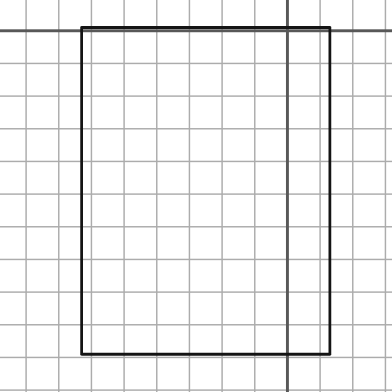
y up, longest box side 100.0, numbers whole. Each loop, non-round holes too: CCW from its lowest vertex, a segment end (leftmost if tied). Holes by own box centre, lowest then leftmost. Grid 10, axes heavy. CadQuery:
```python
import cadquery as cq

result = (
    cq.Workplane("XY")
    .moveTo(-63.0, -99.0)
    .lineTo(13.0, -99.0)
    .lineTo(13.0, 1.0)
    .lineTo(-63.0, 1.0)
    .close()
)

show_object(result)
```